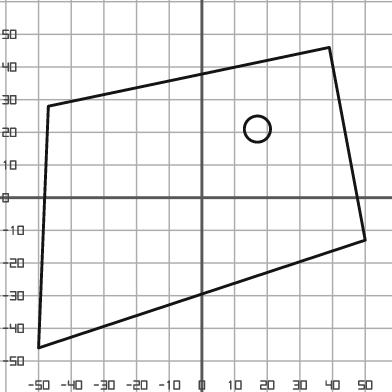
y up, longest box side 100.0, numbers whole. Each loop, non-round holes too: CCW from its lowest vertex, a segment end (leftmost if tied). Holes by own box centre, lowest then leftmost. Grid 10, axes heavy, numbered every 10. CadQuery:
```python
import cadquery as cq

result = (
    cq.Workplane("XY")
    .moveTo(-50.0, -46.0)
    .lineTo(50.0, -13.0)
    .lineTo(39.0, 46.0)
    .lineTo(-47.0, 28.0)
    .close()
    .moveTo(17.0, 21.0)
    .circle(4.0)
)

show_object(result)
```